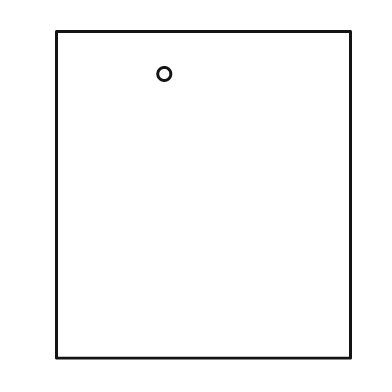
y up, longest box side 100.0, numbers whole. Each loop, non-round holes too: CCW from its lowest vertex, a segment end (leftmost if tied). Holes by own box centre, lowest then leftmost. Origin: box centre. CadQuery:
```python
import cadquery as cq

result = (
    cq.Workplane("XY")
    .moveTo(-45.0, -50.0)
    .lineTo(45.0, -50.0)
    .lineTo(45.0, 50.0)
    .lineTo(-45.0, 50.0)
    .close()
    .moveTo(-12.0, 37.0)
    .circle(2.0)
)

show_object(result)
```